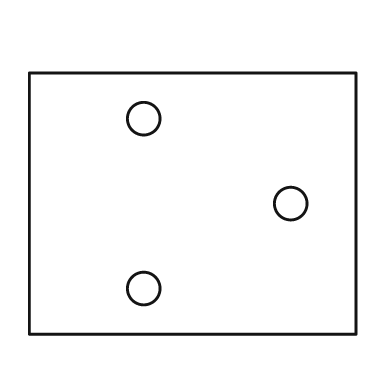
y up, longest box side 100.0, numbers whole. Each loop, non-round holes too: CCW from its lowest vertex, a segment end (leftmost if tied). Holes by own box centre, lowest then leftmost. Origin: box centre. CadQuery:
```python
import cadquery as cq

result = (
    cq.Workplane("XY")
    .moveTo(-50.0, -40.0)
    .lineTo(50.0, -40.0)
    .lineTo(50.0, 40.0)
    .lineTo(-50.0, 40.0)
    .close()
    .moveTo(-15.0, -26.0)
    .circle(5.0)
    .moveTo(30.0, 0.0)
    .circle(5.0)
    .moveTo(-15.0, 26.0)
    .circle(5.0)
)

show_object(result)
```